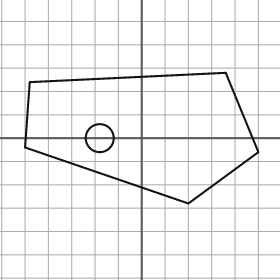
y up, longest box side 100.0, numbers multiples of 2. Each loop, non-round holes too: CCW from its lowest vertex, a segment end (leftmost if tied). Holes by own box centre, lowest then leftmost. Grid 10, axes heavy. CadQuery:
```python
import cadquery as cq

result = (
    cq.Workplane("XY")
    .moveTo(20.0, -28.0)
    .lineTo(50.0, -6.0)
    .lineTo(36.0, 28.0)
    .lineTo(-48.0, 24.0)
    .lineTo(-50.0, -4.0)
    .close()
    .moveTo(-18.0, 0.0)
    .circle(6.0)
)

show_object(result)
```